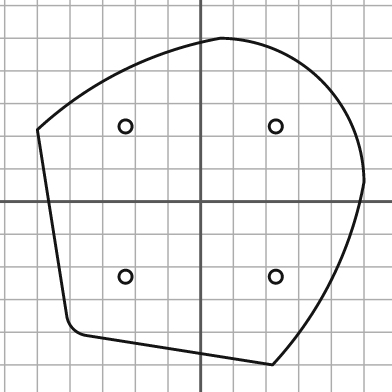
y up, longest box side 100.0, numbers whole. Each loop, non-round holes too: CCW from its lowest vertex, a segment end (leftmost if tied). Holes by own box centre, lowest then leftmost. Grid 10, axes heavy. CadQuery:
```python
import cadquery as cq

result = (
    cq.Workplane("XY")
    .moveTo(22.0, -50.0)
    .threePointArc((40.0, -24.0), (50.0, 6.0))
    .threePointArc((37.0, 37.0), (6.0, 50.0))
    .threePointArc((-24.0, 40.0), (-50.0, 22.0))
    .lineTo(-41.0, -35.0)
    .threePointArc((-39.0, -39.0), (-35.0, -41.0))
    .close()
    .moveTo(-23.0, -23.0)
    .circle(2.0)
    .moveTo(23.0, -23.0)
    .circle(2.0)
    .moveTo(-23.0, 23.0)
    .circle(2.0)
    .moveTo(23.0, 23.0)
    .circle(2.0)
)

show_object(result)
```